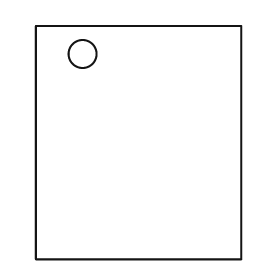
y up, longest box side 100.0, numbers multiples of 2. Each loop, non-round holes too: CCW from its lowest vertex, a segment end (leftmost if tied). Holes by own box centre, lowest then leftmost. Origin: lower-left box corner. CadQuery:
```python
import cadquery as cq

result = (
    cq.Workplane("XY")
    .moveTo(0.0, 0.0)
    .lineTo(88.0, 0.0)
    .lineTo(88.0, 100.0)
    .lineTo(0.0, 100.0)
    .close()
    .moveTo(20.0, 88.0)
    .circle(6.0)
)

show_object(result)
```